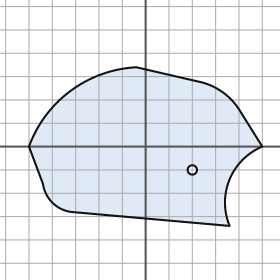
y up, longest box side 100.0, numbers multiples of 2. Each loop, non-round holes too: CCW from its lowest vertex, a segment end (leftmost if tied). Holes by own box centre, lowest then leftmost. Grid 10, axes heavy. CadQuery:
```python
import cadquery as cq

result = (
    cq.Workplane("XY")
    .moveTo(36.0, -34.0)
    .threePointArc((36.0, -14.0), (50.0, 0.0))
    .lineTo(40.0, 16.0)
    .threePointArc((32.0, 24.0), (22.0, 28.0))
    .lineTo(-4.0, 34.0)
    .threePointArc((-32.0, 24.0), (-50.0, 0.0))
    .lineTo(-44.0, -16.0)
    .threePointArc((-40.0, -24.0), (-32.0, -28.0))
    .close()
    .moveTo(20.0, -10.0)
    .circle(2.0)
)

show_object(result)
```